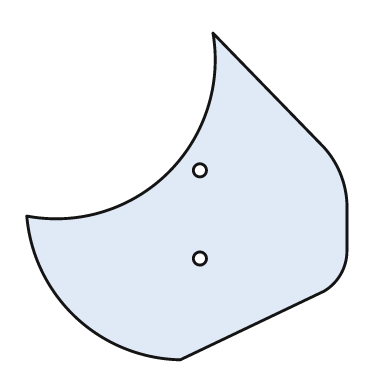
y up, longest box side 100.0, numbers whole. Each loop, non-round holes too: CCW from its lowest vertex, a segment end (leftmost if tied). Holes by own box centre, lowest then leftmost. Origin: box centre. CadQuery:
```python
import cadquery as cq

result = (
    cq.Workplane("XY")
    .moveTo(-2.0, -50.0)
    .lineTo(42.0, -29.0)
    .threePointArc((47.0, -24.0), (49.0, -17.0))
    .lineTo(49.0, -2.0)
    .threePointArc((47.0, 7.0), (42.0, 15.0))
    .lineTo(8.0, 50.0)
    .threePointArc((-6.0, 7.0), (-49.0, -6.0))
    .threePointArc((-34.0, -37.0), (-2.0, -50.0))
    .close()
    .moveTo(4.0, -19.0)
    .circle(2.0)
    .moveTo(4.0, 8.0)
    .circle(2.0)
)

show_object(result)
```